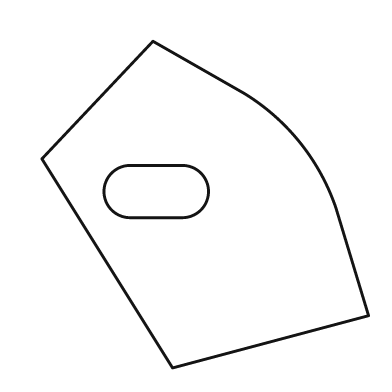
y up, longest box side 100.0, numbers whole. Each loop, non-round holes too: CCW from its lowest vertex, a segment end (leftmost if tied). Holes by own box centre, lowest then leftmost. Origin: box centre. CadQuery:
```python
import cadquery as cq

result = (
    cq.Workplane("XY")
    .moveTo(-10.0, -50.0)
    .lineTo(50.0, -34.0)
    .lineTo(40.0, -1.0)
    .threePointArc((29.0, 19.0), (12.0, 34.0))
    .lineTo(-16.0, 50.0)
    .lineTo(-50.0, 14.0)
    .close()
    .moveTo(-23.0, -4.0)
    .lineTo(-7.0, -4.0)
    .threePointArc((1.0, 4.0), (-7.0, 12.0))
    .lineTo(-23.0, 12.0)
    .threePointArc((-31.0, 4.0), (-23.0, -4.0))
    .close()
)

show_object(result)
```